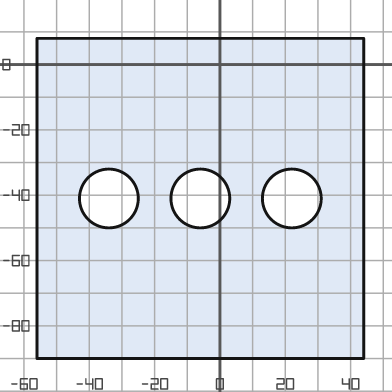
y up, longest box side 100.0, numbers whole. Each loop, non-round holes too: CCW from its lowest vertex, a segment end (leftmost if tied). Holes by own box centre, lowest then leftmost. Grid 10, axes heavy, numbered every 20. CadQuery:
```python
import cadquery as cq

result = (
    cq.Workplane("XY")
    .moveTo(-56.0, -90.0)
    .lineTo(44.0, -90.0)
    .lineTo(44.0, 8.0)
    .lineTo(-56.0, 8.0)
    .close()
    .moveTo(-34.0, -41.0)
    .circle(9.0)
    .moveTo(-6.0, -41.0)
    .circle(9.0)
    .moveTo(22.0, -41.0)
    .circle(9.0)
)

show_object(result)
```